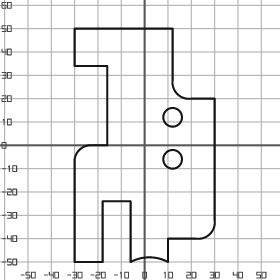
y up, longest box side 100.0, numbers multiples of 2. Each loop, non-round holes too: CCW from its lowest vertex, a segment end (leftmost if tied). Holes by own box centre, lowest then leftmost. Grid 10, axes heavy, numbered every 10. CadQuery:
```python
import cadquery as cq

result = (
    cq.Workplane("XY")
    .moveTo(-30.0, -50.0)
    .lineTo(-18.0, -50.0)
    .lineTo(-18.0, -24.0)
    .lineTo(-6.0, -24.0)
    .lineTo(-6.0, -50.0)
    .threePointArc((2.0, -48.0), (10.0, -50.0))
    .lineTo(10.0, -40.0)
    .lineTo(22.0, -40.0)
    .threePointArc((28.0, -38.0), (30.0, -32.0))
    .lineTo(30.0, 20.0)
    .lineTo(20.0, 20.0)
    .threePointArc((14.0, 22.0), (12.0, 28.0))
    .lineTo(12.0, 50.0)
    .lineTo(-30.0, 50.0)
    .lineTo(-30.0, 34.0)
    .lineTo(-16.0, 34.0)
    .lineTo(-16.0, 0.0)
    .lineTo(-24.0, 0.0)
    .threePointArc((-28.0, -2.0), (-30.0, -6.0))
    .close()
    .moveTo(12.0, -6.0)
    .circle(4.0)
    .moveTo(12.0, 12.0)
    .circle(4.0)
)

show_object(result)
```